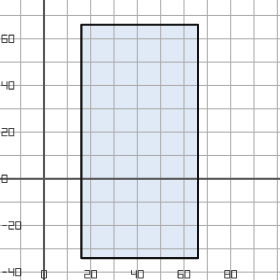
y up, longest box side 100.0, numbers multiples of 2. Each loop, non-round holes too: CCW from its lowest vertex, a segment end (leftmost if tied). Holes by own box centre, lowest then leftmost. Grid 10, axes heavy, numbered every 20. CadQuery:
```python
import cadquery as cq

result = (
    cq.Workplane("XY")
    .moveTo(16.0, -34.0)
    .lineTo(66.0, -34.0)
    .lineTo(66.0, 66.0)
    .lineTo(16.0, 66.0)
    .close()
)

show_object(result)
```